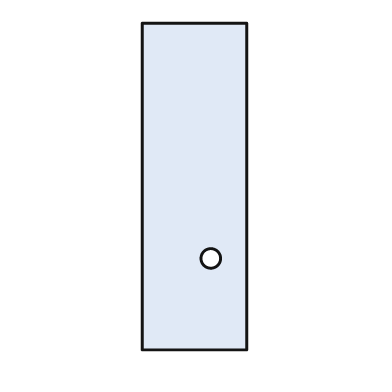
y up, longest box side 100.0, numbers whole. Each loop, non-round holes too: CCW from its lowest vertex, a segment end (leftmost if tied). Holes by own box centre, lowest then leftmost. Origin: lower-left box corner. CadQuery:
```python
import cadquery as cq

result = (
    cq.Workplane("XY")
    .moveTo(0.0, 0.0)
    .lineTo(32.0, 0.0)
    .lineTo(32.0, 100.0)
    .lineTo(0.0, 100.0)
    .close()
    .moveTo(21.0, 28.0)
    .circle(3.0)
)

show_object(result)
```